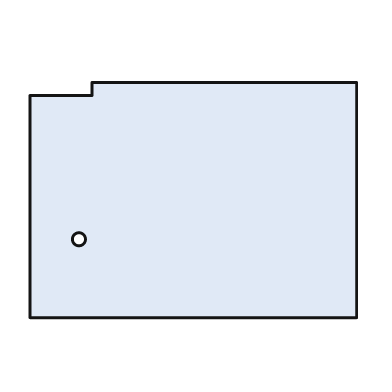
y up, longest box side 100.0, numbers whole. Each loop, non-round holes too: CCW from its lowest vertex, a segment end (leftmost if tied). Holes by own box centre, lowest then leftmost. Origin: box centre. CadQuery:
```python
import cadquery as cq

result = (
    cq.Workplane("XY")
    .moveTo(-50.0, -36.0)
    .lineTo(50.0, -36.0)
    .lineTo(50.0, 36.0)
    .lineTo(-31.0, 36.0)
    .lineTo(-31.0, 32.0)
    .lineTo(-50.0, 32.0)
    .close()
    .moveTo(-35.0, -12.0)
    .circle(2.0)
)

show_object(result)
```